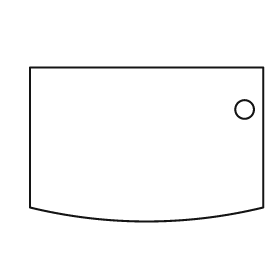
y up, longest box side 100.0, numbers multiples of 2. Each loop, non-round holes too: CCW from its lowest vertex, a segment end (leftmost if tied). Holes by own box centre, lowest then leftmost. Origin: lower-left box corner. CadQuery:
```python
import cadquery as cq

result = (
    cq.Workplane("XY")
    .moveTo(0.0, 6.0)
    .threePointArc((50.0, 0.0), (100.0, 6.0))
    .lineTo(100.0, 66.0)
    .lineTo(0.0, 66.0)
    .close()
    .moveTo(92.0, 48.0)
    .circle(4.0)
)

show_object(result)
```